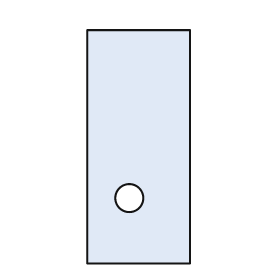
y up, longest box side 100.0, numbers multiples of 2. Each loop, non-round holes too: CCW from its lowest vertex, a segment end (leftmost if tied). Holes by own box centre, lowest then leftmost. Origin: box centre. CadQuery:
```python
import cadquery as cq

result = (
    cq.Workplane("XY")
    .moveTo(-22.0, -50.0)
    .lineTo(22.0, -50.0)
    .lineTo(22.0, 50.0)
    .lineTo(-22.0, 50.0)
    .close()
    .moveTo(-4.0, -22.0)
    .circle(6.0)
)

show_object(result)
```